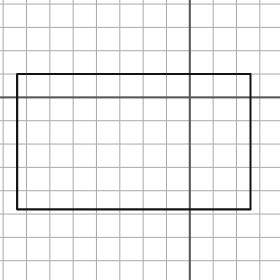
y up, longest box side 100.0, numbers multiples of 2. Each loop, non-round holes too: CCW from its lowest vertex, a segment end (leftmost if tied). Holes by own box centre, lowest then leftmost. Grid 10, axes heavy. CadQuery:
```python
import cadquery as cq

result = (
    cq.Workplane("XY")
    .moveTo(-74.0, -48.0)
    .lineTo(26.0, -48.0)
    .lineTo(26.0, 10.0)
    .lineTo(-74.0, 10.0)
    .close()
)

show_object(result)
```